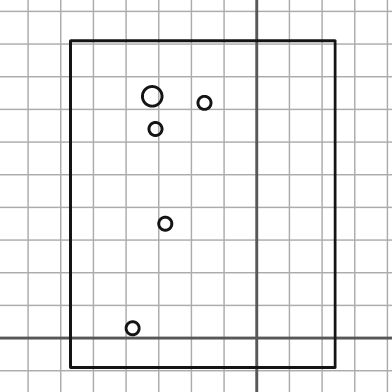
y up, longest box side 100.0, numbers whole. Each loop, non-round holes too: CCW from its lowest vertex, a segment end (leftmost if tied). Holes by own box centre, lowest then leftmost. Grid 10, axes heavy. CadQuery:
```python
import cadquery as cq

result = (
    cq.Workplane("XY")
    .moveTo(-57.0, -9.0)
    .lineTo(24.0, -9.0)
    .lineTo(24.0, 91.0)
    .lineTo(-57.0, 91.0)
    .close()
    .moveTo(-38.0, 3.0)
    .circle(2.0)
    .moveTo(-28.0, 35.0)
    .circle(2.0)
    .moveTo(-31.0, 64.0)
    .circle(2.0)
    .moveTo(-16.0, 72.0)
    .circle(2.0)
    .moveTo(-32.0, 74.0)
    .circle(3.0)
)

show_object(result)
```